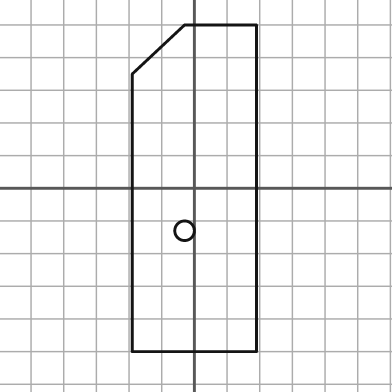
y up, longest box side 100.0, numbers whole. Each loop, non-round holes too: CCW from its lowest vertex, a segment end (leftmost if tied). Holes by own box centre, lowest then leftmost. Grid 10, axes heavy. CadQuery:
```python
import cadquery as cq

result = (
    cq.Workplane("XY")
    .moveTo(-19.0, -50.0)
    .lineTo(19.0, -50.0)
    .lineTo(19.0, 50.0)
    .lineTo(-3.0, 50.0)
    .lineTo(-19.0, 35.0)
    .close()
    .moveTo(-3.0, -13.0)
    .circle(3.0)
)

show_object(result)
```